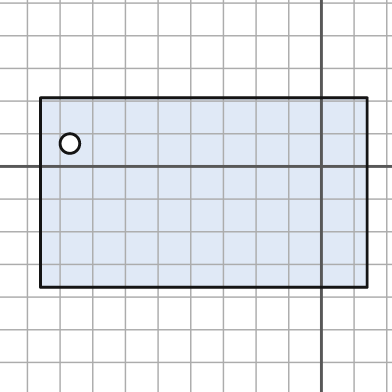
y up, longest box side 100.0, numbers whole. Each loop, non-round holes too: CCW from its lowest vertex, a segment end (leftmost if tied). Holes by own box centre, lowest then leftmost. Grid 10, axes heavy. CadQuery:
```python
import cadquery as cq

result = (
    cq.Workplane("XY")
    .moveTo(-86.0, -37.0)
    .lineTo(14.0, -37.0)
    .lineTo(14.0, 21.0)
    .lineTo(-86.0, 21.0)
    .close()
    .moveTo(-77.0, 7.0)
    .circle(3.0)
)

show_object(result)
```